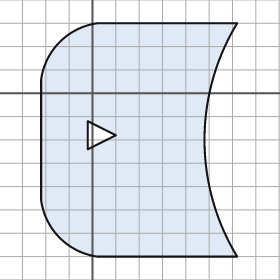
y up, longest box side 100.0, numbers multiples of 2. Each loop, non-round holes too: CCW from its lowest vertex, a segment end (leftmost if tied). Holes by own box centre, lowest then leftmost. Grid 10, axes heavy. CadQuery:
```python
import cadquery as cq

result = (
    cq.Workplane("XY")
    .moveTo(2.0, -70.0)
    .lineTo(62.0, -70.0)
    .threePointArc((48.0, -20.0), (62.0, 30.0))
    .lineTo(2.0, 30.0)
    .threePointArc((-14.0, 22.0), (-22.0, 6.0))
    .lineTo(-22.0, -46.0)
    .threePointArc((-14.0, -62.0), (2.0, -70.0))
    .close()
    .moveTo(-2.0, -24.0)
    .lineTo(10.0, -18.0)
    .lineTo(-2.0, -12.0)
    .close()
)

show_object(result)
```